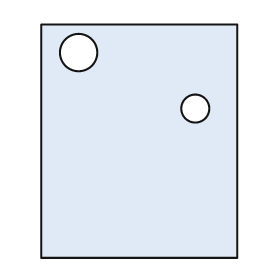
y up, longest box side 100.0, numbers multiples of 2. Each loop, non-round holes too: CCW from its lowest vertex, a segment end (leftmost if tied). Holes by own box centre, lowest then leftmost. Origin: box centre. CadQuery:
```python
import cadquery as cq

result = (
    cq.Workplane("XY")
    .moveTo(-42.0, -50.0)
    .lineTo(42.0, -50.0)
    .lineTo(42.0, 50.0)
    .lineTo(-42.0, 50.0)
    .close()
    .moveTo(24.0, 14.0)
    .circle(6.0)
    .moveTo(-26.0, 38.0)
    .circle(8.0)
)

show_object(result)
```